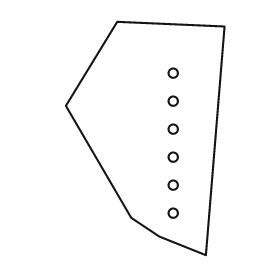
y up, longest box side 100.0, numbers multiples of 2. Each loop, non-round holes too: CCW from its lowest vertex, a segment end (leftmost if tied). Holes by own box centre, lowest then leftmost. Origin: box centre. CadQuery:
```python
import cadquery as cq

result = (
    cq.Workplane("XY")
    .moveTo(26.0, -50.0)
    .lineTo(34.0, 48.0)
    .lineTo(-12.0, 50.0)
    .lineTo(-34.0, 14.0)
    .lineTo(-6.0, -34.0)
    .lineTo(6.0, -42.0)
    .close()
    .moveTo(12.0, -32.0)
    .circle(2.0)
    .moveTo(12.0, -20.0)
    .circle(2.0)
    .moveTo(12.0, -8.0)
    .circle(2.0)
    .moveTo(12.0, 4.0)
    .circle(2.0)
    .moveTo(12.0, 16.0)
    .circle(2.0)
    .moveTo(12.0, 28.0)
    .circle(2.0)
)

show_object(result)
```